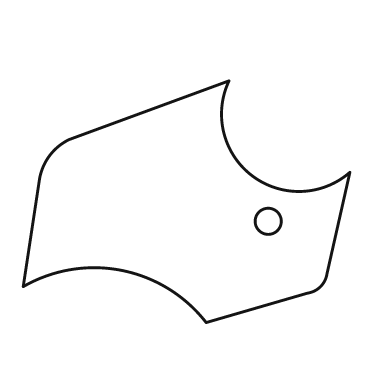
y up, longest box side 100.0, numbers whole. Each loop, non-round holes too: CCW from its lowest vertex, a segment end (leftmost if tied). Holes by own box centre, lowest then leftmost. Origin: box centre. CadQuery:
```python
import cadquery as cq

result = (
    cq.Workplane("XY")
    .moveTo(6.0, -37.0)
    .lineTo(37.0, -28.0)
    .threePointArc((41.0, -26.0), (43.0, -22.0))
    .lineTo(50.0, 9.0)
    .threePointArc((20.0, 8.0), (13.0, 37.0))
    .lineTo(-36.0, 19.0)
    .threePointArc((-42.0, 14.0), (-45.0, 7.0))
    .lineTo(-50.0, -26.0)
    .threePointArc((-20.0, -21.0), (6.0, -37.0))
    .close()
    .moveTo(25.0, -6.0)
    .circle(4.0)
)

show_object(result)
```